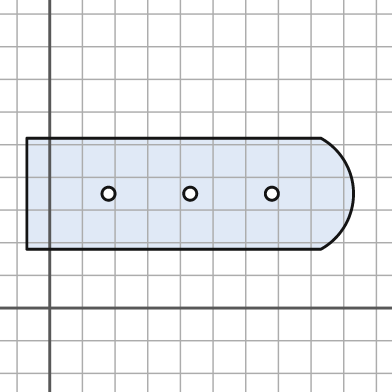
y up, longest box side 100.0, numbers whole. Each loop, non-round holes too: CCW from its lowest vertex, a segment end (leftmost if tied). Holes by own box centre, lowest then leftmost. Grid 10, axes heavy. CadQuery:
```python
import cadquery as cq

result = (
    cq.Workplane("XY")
    .moveTo(-7.0, 18.0)
    .lineTo(83.0, 18.0)
    .threePointArc((93.0, 35.0), (83.0, 52.0))
    .lineTo(-7.0, 52.0)
    .close()
    .moveTo(18.0, 35.0)
    .circle(2.0)
    .moveTo(43.0, 35.0)
    .circle(2.0)
    .moveTo(68.0, 35.0)
    .circle(2.0)
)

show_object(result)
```